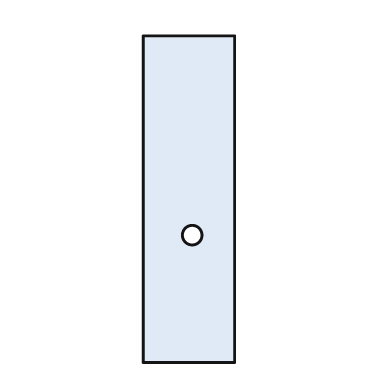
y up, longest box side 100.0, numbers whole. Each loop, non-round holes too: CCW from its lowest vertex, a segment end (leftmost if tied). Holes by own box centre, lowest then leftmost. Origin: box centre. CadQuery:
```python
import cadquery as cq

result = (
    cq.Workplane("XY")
    .moveTo(-14.0, -50.0)
    .lineTo(14.0, -50.0)
    .lineTo(14.0, 50.0)
    .lineTo(-14.0, 50.0)
    .close()
    .moveTo(1.0, -11.0)
    .circle(3.0)
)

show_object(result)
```